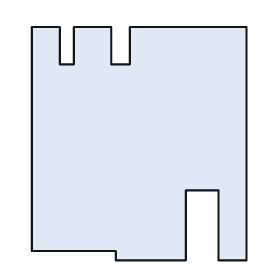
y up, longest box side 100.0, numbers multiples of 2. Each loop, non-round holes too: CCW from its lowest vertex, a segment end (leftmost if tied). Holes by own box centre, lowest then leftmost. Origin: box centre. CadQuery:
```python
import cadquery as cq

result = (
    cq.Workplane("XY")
    .moveTo(-10.0, -50.0)
    .lineTo(20.0, -50.0)
    .lineTo(20.0, -20.0)
    .lineTo(34.0, -20.0)
    .lineTo(34.0, -50.0)
    .lineTo(46.0, -50.0)
    .lineTo(46.0, 50.0)
    .lineTo(-4.0, 50.0)
    .lineTo(-4.0, 34.0)
    .lineTo(-12.0, 34.0)
    .lineTo(-12.0, 50.0)
    .lineTo(-28.0, 50.0)
    .lineTo(-28.0, 34.0)
    .lineTo(-34.0, 34.0)
    .lineTo(-34.0, 50.0)
    .lineTo(-46.0, 50.0)
    .lineTo(-46.0, -46.0)
    .lineTo(-10.0, -46.0)
    .close()
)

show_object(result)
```